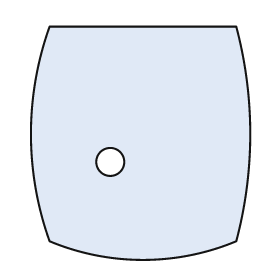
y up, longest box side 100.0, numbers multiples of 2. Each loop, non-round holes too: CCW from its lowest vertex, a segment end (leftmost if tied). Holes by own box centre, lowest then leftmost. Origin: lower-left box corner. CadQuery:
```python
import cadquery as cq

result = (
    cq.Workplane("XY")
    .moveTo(8.0, 8.0)
    .threePointArc((48.0, 0.0), (88.0, 8.0))
    .threePointArc((94.0, 54.0), (88.0, 100.0))
    .lineTo(8.0, 100.0)
    .threePointArc((0.0, 54.0), (8.0, 8.0))
    .close()
    .moveTo(34.0, 42.0)
    .circle(6.0)
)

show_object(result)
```